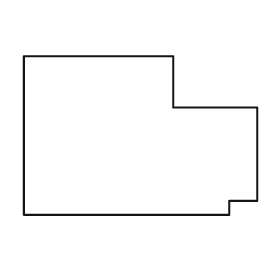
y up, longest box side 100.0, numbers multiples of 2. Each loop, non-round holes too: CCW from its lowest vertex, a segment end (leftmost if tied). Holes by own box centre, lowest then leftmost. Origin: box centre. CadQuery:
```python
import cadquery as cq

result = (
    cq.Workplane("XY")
    .moveTo(-50.0, -34.0)
    .lineTo(38.0, -34.0)
    .lineTo(38.0, -28.0)
    .lineTo(50.0, -28.0)
    .lineTo(50.0, 12.0)
    .lineTo(14.0, 12.0)
    .lineTo(14.0, 34.0)
    .lineTo(-50.0, 34.0)
    .close()
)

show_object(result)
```